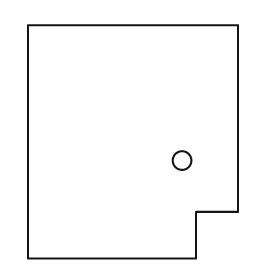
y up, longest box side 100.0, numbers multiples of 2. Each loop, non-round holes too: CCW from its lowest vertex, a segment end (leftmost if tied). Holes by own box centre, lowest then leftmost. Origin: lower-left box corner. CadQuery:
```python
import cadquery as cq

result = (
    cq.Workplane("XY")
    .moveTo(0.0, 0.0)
    .lineTo(72.0, 0.0)
    .lineTo(72.0, 20.0)
    .lineTo(90.0, 20.0)
    .lineTo(90.0, 100.0)
    .lineTo(0.0, 100.0)
    .close()
    .moveTo(66.0, 42.0)
    .circle(4.0)
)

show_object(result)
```